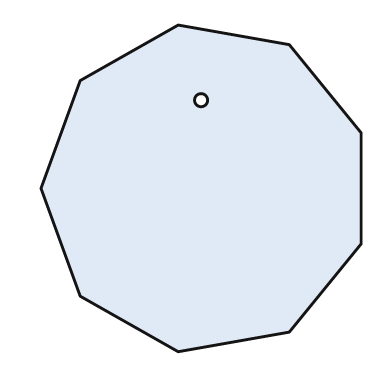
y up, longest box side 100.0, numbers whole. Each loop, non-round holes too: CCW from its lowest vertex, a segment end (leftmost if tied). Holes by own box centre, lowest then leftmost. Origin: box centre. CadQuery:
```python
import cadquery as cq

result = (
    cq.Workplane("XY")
    .moveTo(-7.0, -50.0)
    .lineTo(27.0, -44.0)
    .lineTo(49.0, -17.0)
    .lineTo(49.0, 17.0)
    .lineTo(27.0, 44.0)
    .lineTo(-7.0, 50.0)
    .lineTo(-37.0, 33.0)
    .lineTo(-49.0, 0.0)
    .lineTo(-37.0, -33.0)
    .close()
    .moveTo(0.0, 27.0)
    .circle(2.0)
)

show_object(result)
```